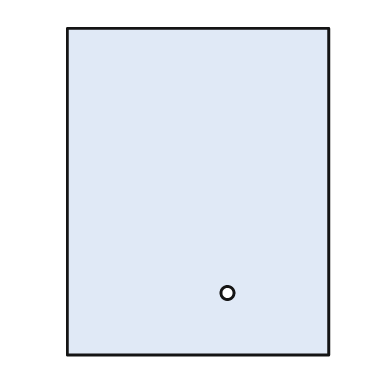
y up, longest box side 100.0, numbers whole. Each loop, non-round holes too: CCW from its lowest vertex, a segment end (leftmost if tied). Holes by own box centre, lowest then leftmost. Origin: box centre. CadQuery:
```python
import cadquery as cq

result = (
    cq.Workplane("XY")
    .moveTo(-40.0, -50.0)
    .lineTo(40.0, -50.0)
    .lineTo(40.0, 50.0)
    .lineTo(-40.0, 50.0)
    .close()
    .moveTo(9.0, -31.0)
    .circle(2.0)
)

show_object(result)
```